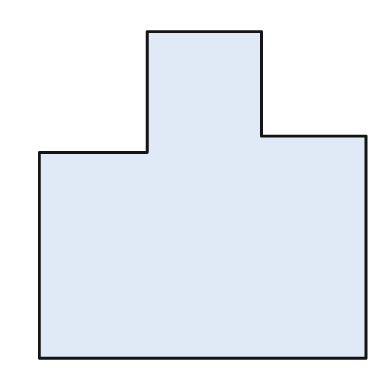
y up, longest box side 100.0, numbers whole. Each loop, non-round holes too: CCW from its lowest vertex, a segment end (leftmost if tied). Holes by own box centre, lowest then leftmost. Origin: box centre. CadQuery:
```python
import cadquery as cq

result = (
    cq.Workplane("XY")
    .moveTo(-50.0, -50.0)
    .lineTo(50.0, -50.0)
    .lineTo(50.0, 18.0)
    .lineTo(18.0, 18.0)
    .lineTo(18.0, 50.0)
    .lineTo(-17.0, 50.0)
    .lineTo(-17.0, 13.0)
    .lineTo(-50.0, 13.0)
    .close()
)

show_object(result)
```